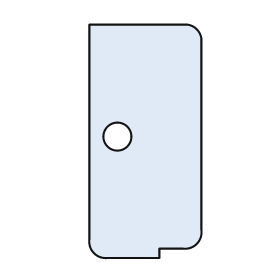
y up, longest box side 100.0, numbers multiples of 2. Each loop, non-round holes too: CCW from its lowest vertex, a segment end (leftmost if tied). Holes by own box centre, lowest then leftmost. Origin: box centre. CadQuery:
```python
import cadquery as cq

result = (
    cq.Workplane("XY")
    .moveTo(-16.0, -50.0)
    .lineTo(6.0, -50.0)
    .lineTo(6.0, -46.0)
    .lineTo(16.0, -46.0)
    .threePointArc((22.0, -44.0), (24.0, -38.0))
    .lineTo(24.0, 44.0)
    .threePointArc((22.0, 48.0), (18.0, 50.0))
    .lineTo(-24.0, 50.0)
    .lineTo(-24.0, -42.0)
    .threePointArc((-22.0, -48.0), (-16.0, -50.0))
    .close()
    .moveTo(-12.0, 2.0)
    .circle(6.0)
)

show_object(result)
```